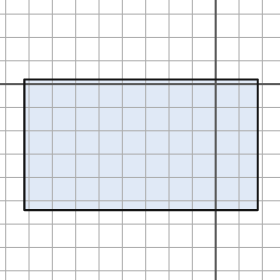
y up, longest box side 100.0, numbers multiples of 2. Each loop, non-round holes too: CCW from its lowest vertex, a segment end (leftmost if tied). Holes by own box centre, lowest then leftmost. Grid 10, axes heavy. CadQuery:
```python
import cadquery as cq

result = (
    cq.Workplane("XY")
    .moveTo(-82.0, -54.0)
    .lineTo(18.0, -54.0)
    .lineTo(18.0, 2.0)
    .lineTo(-82.0, 2.0)
    .close()
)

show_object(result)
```